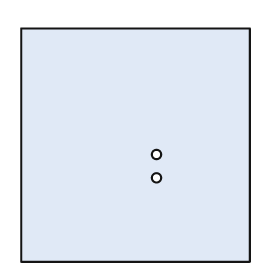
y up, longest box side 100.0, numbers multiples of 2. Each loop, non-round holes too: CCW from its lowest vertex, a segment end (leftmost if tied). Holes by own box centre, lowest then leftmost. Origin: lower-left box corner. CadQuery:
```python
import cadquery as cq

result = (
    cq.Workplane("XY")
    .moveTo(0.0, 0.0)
    .lineTo(98.0, 0.0)
    .lineTo(98.0, 100.0)
    .lineTo(0.0, 100.0)
    .close()
    .moveTo(58.0, 36.0)
    .circle(2.0)
    .moveTo(58.0, 46.0)
    .circle(2.0)
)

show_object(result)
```